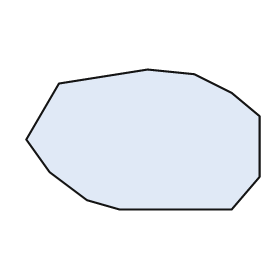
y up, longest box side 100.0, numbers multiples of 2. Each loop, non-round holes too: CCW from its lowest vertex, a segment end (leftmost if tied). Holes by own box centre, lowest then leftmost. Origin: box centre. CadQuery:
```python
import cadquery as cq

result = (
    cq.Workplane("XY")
    .moveTo(-10.0, -30.0)
    .lineTo(38.0, -30.0)
    .lineTo(50.0, -16.0)
    .lineTo(50.0, 10.0)
    .lineTo(38.0, 20.0)
    .lineTo(22.0, 28.0)
    .lineTo(2.0, 30.0)
    .lineTo(-36.0, 24.0)
    .lineTo(-50.0, 0.0)
    .lineTo(-40.0, -14.0)
    .lineTo(-24.0, -26.0)
    .close()
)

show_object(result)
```